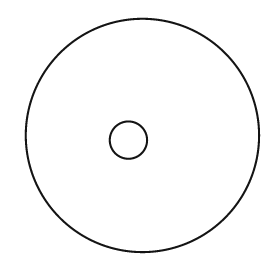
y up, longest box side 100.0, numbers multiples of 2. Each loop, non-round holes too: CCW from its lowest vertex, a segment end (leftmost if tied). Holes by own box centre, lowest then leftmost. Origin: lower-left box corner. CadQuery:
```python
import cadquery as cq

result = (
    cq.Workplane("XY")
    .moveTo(50.0, 50.0)
    .circle(50.0)
    .moveTo(44.0, 48.0)
    .circle(8.0)
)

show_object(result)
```